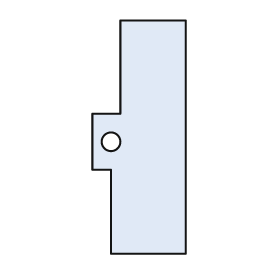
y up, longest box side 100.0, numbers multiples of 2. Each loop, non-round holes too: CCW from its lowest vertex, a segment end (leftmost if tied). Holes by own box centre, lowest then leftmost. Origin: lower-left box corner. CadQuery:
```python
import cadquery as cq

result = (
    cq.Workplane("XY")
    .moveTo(8.0, 0.0)
    .lineTo(40.0, 0.0)
    .lineTo(40.0, 100.0)
    .lineTo(12.0, 100.0)
    .lineTo(12.0, 60.0)
    .lineTo(0.0, 60.0)
    .lineTo(0.0, 36.0)
    .lineTo(8.0, 36.0)
    .close()
    .moveTo(8.0, 48.0)
    .circle(4.0)
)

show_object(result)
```